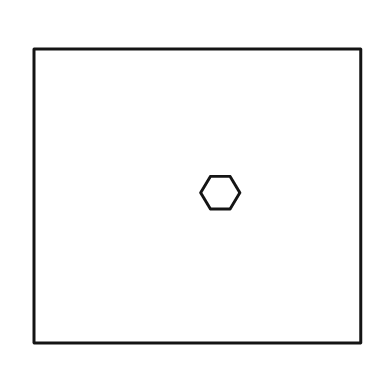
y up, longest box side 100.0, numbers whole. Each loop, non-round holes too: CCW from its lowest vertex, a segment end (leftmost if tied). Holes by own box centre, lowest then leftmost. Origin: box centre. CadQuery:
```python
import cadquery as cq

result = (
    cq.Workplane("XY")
    .moveTo(-50.0, -45.0)
    .lineTo(50.0, -45.0)
    .lineTo(50.0, 45.0)
    .lineTo(-50.0, 45.0)
    .close()
    .moveTo(4.0, -4.0)
    .lineTo(10.0, -4.0)
    .lineTo(13.0, 1.0)
    .lineTo(10.0, 6.0)
    .lineTo(4.0, 6.0)
    .lineTo(1.0, 1.0)
    .close()
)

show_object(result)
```